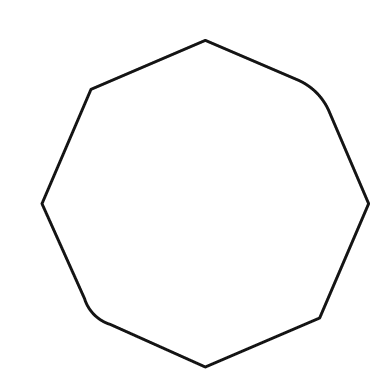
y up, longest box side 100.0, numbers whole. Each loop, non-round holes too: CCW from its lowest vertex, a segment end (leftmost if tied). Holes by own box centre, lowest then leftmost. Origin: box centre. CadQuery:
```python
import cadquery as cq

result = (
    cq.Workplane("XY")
    .moveTo(0.0, -50.0)
    .lineTo(35.0, -35.0)
    .lineTo(50.0, 0.0)
    .lineTo(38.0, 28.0)
    .threePointArc((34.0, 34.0), (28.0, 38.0))
    .lineTo(0.0, 50.0)
    .lineTo(-35.0, 35.0)
    .lineTo(-50.0, 0.0)
    .lineTo(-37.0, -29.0)
    .threePointArc((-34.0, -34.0), (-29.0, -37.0))
    .close()
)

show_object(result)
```